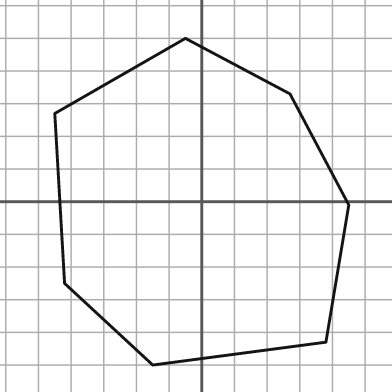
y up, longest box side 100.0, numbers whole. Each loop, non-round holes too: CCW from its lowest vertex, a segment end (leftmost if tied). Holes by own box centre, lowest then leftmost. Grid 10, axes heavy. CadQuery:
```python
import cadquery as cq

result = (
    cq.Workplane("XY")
    .moveTo(-15.0, -50.0)
    .lineTo(38.0, -43.0)
    .lineTo(45.0, -1.0)
    .lineTo(27.0, 33.0)
    .lineTo(-5.0, 50.0)
    .lineTo(-45.0, 27.0)
    .lineTo(-42.0, -25.0)
    .close()
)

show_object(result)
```